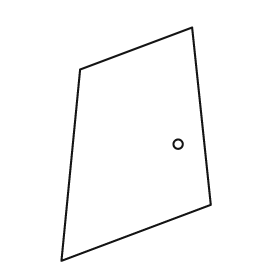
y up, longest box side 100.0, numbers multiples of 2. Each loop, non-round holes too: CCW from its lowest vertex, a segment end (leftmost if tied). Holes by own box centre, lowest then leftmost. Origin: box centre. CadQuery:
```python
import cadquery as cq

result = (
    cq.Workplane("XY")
    .moveTo(-32.0, -50.0)
    .lineTo(32.0, -26.0)
    .lineTo(24.0, 50.0)
    .lineTo(-24.0, 32.0)
    .close()
    .moveTo(18.0, 0.0)
    .circle(2.0)
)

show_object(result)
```